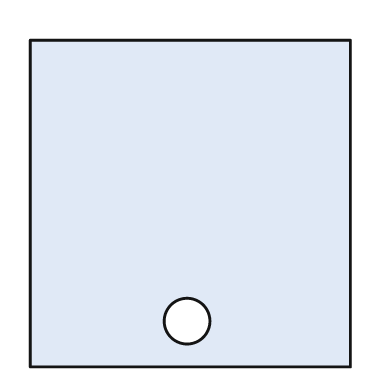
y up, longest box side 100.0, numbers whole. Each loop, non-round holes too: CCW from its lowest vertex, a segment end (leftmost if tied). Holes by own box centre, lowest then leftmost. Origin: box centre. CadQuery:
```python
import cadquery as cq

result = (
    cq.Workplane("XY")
    .moveTo(-49.0, -50.0)
    .lineTo(49.0, -50.0)
    .lineTo(49.0, 50.0)
    .lineTo(-49.0, 50.0)
    .close()
    .moveTo(-1.0, -36.0)
    .circle(7.0)
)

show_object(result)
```